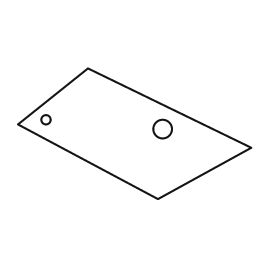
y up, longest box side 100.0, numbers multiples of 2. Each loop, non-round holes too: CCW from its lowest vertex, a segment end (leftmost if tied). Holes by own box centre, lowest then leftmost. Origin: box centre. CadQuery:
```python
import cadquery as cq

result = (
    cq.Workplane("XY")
    .moveTo(10.0, -28.0)
    .lineTo(50.0, -6.0)
    .lineTo(-20.0, 28.0)
    .lineTo(-50.0, 4.0)
    .close()
    .moveTo(12.0, 2.0)
    .circle(4.0)
    .moveTo(-38.0, 6.0)
    .circle(2.0)
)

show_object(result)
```